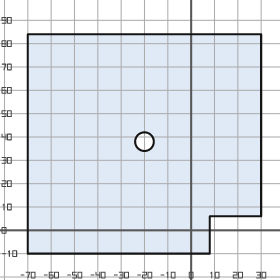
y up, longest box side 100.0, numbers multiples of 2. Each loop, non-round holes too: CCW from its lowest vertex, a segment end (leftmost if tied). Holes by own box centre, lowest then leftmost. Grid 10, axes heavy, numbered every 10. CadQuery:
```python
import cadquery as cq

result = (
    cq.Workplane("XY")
    .moveTo(-70.0, -10.0)
    .lineTo(8.0, -10.0)
    .lineTo(8.0, 6.0)
    .lineTo(30.0, 6.0)
    .lineTo(30.0, 84.0)
    .lineTo(-70.0, 84.0)
    .close()
    .moveTo(-20.0, 38.0)
    .circle(4.0)
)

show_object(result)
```